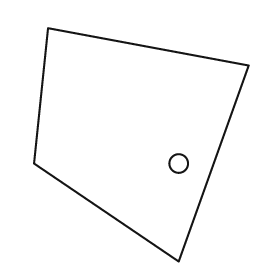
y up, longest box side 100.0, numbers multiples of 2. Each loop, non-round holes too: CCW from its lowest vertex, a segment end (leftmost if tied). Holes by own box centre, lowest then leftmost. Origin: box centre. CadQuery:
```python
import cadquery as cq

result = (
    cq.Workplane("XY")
    .moveTo(16.0, -50.0)
    .lineTo(46.0, 34.0)
    .lineTo(-40.0, 50.0)
    .lineTo(-46.0, -8.0)
    .close()
    .moveTo(16.0, -8.0)
    .circle(4.0)
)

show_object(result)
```